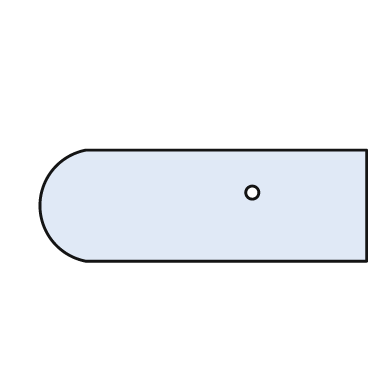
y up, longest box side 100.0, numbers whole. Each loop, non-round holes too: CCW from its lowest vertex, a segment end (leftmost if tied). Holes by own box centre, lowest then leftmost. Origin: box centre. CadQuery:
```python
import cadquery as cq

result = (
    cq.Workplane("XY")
    .moveTo(-36.0, -17.0)
    .lineTo(50.0, -17.0)
    .lineTo(50.0, 17.0)
    .lineTo(-36.0, 17.0)
    .threePointArc((-50.0, 0.0), (-36.0, -17.0))
    .close()
    .moveTo(15.0, 4.0)
    .circle(2.0)
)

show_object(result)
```